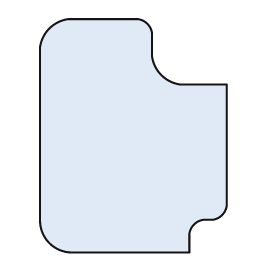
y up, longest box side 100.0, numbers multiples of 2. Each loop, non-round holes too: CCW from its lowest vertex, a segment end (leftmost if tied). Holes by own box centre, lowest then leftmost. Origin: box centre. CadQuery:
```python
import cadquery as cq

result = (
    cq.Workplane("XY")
    .moveTo(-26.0, -50.0)
    .lineTo(24.0, -50.0)
    .lineTo(24.0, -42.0)
    .threePointArc((26.0, -38.0), (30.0, -36.0))
    .lineTo(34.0, -36.0)
    .threePointArc((38.0, -34.0), (40.0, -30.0))
    .lineTo(40.0, 22.0)
    .lineTo(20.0, 22.0)
    .threePointArc((12.0, 26.0), (8.0, 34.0))
    .lineTo(8.0, 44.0)
    .threePointArc((6.0, 48.0), (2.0, 50.0))
    .lineTo(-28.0, 50.0)
    .threePointArc((-36.0, 46.0), (-40.0, 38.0))
    .lineTo(-40.0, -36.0)
    .threePointArc((-36.0, -46.0), (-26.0, -50.0))
    .close()
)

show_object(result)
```